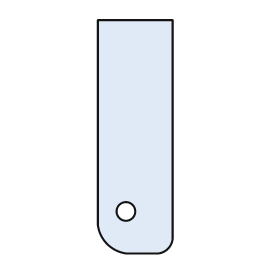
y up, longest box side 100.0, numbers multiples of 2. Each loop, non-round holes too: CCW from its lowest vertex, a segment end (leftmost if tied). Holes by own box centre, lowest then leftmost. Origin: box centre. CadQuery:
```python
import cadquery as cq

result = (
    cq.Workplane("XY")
    .moveTo(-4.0, -50.0)
    .lineTo(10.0, -50.0)
    .threePointArc((14.0, -48.0), (16.0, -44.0))
    .lineTo(16.0, 50.0)
    .lineTo(-16.0, 50.0)
    .lineTo(-16.0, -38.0)
    .threePointArc((-12.0, -46.0), (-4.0, -50.0))
    .close()
    .moveTo(-4.0, -32.0)
    .circle(4.0)
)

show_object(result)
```